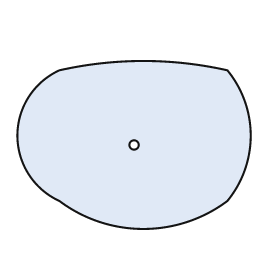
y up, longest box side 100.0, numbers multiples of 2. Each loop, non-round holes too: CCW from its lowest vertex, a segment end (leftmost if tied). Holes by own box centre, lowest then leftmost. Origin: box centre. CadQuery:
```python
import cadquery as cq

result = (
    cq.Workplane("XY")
    .moveTo(-32.0, -24.0)
    .threePointArc((4.0, -36.0), (40.0, -24.0))
    .threePointArc((50.0, 4.0), (40.0, 32.0))
    .threePointArc((4.0, 36.0), (-32.0, 32.0))
    .threePointArc((-50.0, 4.0), (-32.0, -24.0))
    .close()
    .moveTo(0.0, 0.0)
    .circle(2.0)
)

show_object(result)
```